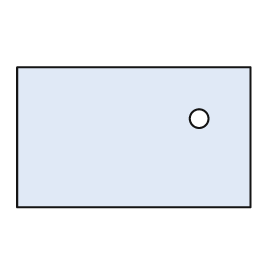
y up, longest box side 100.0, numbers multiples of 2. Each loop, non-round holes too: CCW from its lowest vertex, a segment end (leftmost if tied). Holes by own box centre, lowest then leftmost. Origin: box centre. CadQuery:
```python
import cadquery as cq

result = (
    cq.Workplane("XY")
    .moveTo(-50.0, -30.0)
    .lineTo(50.0, -30.0)
    .lineTo(50.0, 30.0)
    .lineTo(-50.0, 30.0)
    .close()
    .moveTo(28.0, 8.0)
    .circle(4.0)
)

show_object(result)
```